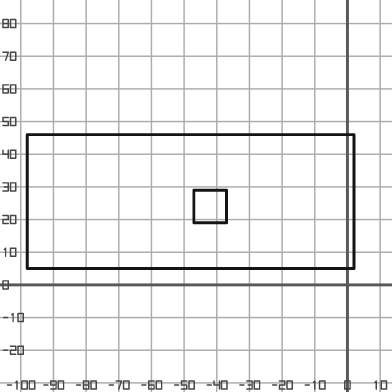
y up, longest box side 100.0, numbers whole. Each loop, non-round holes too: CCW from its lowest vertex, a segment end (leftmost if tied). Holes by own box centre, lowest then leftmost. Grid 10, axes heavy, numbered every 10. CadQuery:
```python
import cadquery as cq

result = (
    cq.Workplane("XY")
    .moveTo(-98.0, 5.0)
    .lineTo(2.0, 5.0)
    .lineTo(2.0, 46.0)
    .lineTo(-98.0, 46.0)
    .close()
    .moveTo(-47.0, 19.0)
    .lineTo(-37.0, 19.0)
    .lineTo(-37.0, 29.0)
    .lineTo(-47.0, 29.0)
    .close()
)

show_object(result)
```